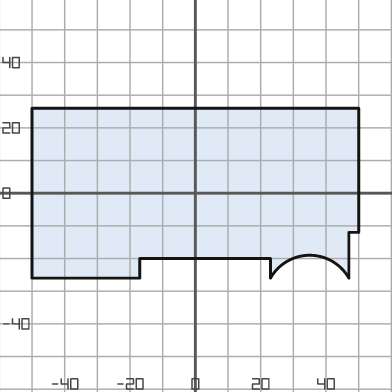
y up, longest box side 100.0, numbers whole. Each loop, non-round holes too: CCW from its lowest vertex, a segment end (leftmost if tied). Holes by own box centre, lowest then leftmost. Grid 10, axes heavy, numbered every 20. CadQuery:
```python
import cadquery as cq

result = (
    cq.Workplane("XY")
    .moveTo(-50.0, -26.0)
    .lineTo(-17.0, -26.0)
    .lineTo(-17.0, -20.0)
    .lineTo(23.0, -20.0)
    .lineTo(23.0, -26.0)
    .threePointArc((35.0, -19.0), (47.0, -26.0))
    .lineTo(47.0, -12.0)
    .lineTo(50.0, -12.0)
    .lineTo(50.0, 26.0)
    .lineTo(-50.0, 26.0)
    .close()
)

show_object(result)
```